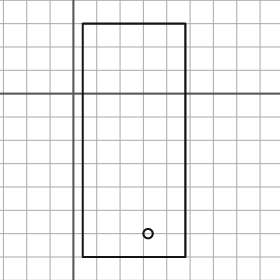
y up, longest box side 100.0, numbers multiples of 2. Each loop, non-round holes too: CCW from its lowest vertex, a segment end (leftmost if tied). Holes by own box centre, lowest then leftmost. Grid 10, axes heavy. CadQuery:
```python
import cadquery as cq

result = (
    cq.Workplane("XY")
    .moveTo(4.0, -70.0)
    .lineTo(48.0, -70.0)
    .lineTo(48.0, 30.0)
    .lineTo(4.0, 30.0)
    .close()
    .moveTo(32.0, -60.0)
    .circle(2.0)
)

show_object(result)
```